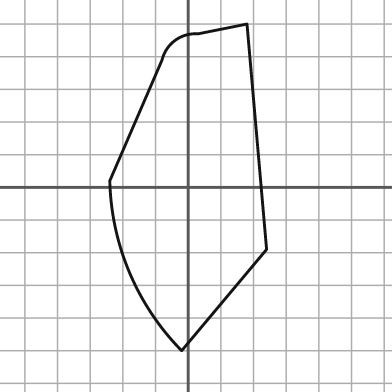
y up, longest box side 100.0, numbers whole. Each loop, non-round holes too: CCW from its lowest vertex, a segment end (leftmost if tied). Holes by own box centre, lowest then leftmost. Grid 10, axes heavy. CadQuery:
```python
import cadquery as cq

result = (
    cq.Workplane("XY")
    .moveTo(-2.0, -50.0)
    .lineTo(24.0, -19.0)
    .lineTo(18.0, 50.0)
    .lineTo(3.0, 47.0)
    .threePointArc((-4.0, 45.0), (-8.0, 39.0))
    .lineTo(-24.0, 2.0)
    .threePointArc((-18.0, -26.0), (-2.0, -50.0))
    .close()
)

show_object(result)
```